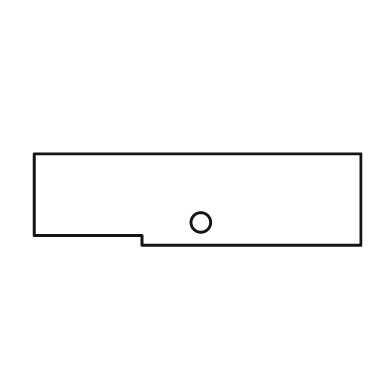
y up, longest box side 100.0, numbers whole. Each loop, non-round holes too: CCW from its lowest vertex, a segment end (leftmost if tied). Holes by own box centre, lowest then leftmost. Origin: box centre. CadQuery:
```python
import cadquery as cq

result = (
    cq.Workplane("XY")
    .moveTo(-17.0, -14.0)
    .lineTo(50.0, -14.0)
    .lineTo(50.0, 14.0)
    .lineTo(-50.0, 14.0)
    .lineTo(-50.0, -11.0)
    .lineTo(-17.0, -11.0)
    .close()
    .moveTo(1.0, -7.0)
    .circle(3.0)
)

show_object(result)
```